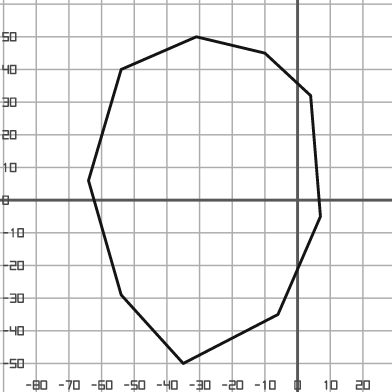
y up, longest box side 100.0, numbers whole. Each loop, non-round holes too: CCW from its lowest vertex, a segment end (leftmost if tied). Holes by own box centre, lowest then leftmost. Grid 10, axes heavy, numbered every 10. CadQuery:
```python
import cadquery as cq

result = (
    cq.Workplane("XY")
    .moveTo(-35.0, -50.0)
    .lineTo(-6.0, -35.0)
    .lineTo(7.0, -5.0)
    .lineTo(4.0, 32.0)
    .lineTo(-10.0, 45.0)
    .lineTo(-31.0, 50.0)
    .lineTo(-54.0, 40.0)
    .lineTo(-64.0, 6.0)
    .lineTo(-54.0, -29.0)
    .close()
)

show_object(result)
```